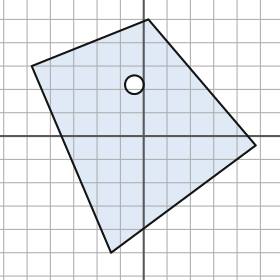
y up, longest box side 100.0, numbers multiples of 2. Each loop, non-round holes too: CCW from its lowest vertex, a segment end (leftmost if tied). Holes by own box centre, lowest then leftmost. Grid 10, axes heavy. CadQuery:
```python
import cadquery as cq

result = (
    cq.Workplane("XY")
    .moveTo(-14.0, -50.0)
    .lineTo(48.0, -4.0)
    .lineTo(2.0, 50.0)
    .lineTo(-48.0, 30.0)
    .close()
    .moveTo(-4.0, 22.0)
    .circle(4.0)
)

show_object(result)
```